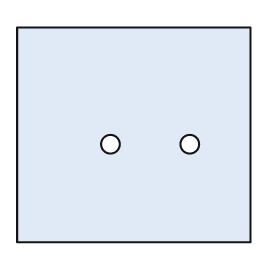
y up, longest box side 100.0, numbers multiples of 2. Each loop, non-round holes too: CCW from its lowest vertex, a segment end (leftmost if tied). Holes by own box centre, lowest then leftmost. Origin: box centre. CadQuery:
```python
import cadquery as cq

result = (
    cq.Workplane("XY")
    .moveTo(-50.0, -46.0)
    .lineTo(50.0, -46.0)
    .lineTo(50.0, 46.0)
    .lineTo(-50.0, 46.0)
    .close()
    .moveTo(-10.0, -4.0)
    .circle(4.0)
    .moveTo(24.0, -4.0)
    .circle(4.0)
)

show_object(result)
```